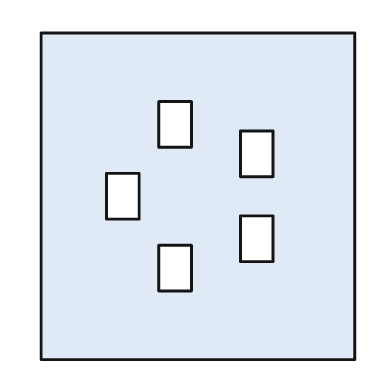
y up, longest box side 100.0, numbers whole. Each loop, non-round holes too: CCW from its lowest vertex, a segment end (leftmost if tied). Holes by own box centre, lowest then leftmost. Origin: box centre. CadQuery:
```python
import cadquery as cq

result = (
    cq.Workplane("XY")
    .moveTo(-48.0, -50.0)
    .lineTo(48.0, -50.0)
    .lineTo(48.0, 50.0)
    .lineTo(-48.0, 50.0)
    .close()
    .moveTo(-12.0, -29.0)
    .lineTo(-2.0, -29.0)
    .lineTo(-2.0, -15.0)
    .lineTo(-12.0, -15.0)
    .close()
    .moveTo(13.0, -20.0)
    .lineTo(23.0, -20.0)
    .lineTo(23.0, -6.0)
    .lineTo(13.0, -6.0)
    .close()
    .moveTo(-28.0, -7.0)
    .lineTo(-18.0, -7.0)
    .lineTo(-18.0, 7.0)
    .lineTo(-28.0, 7.0)
    .close()
    .moveTo(13.0, 6.0)
    .lineTo(23.0, 6.0)
    .lineTo(23.0, 20.0)
    .lineTo(13.0, 20.0)
    .close()
    .moveTo(-12.0, 15.0)
    .lineTo(-2.0, 15.0)
    .lineTo(-2.0, 29.0)
    .lineTo(-12.0, 29.0)
    .close()
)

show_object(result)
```